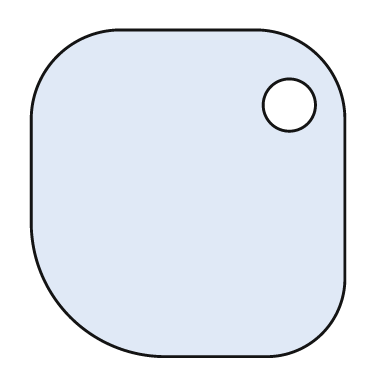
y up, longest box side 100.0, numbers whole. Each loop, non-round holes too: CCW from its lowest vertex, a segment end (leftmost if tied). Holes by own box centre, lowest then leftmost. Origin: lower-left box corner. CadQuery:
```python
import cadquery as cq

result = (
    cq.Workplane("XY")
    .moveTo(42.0, 0.0)
    .lineTo(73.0, 0.0)
    .threePointArc((89.0, 7.0), (96.0, 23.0))
    .lineTo(96.0, 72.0)
    .threePointArc((88.0, 92.0), (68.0, 100.0))
    .lineTo(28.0, 100.0)
    .threePointArc((8.0, 92.0), (0.0, 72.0))
    .lineTo(0.0, 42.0)
    .threePointArc((12.0, 12.0), (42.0, 0.0))
    .close()
    .moveTo(79.0, 77.0)
    .circle(8.0)
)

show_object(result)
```